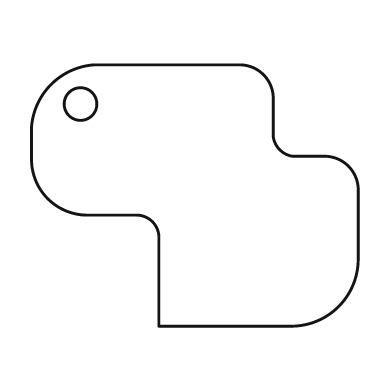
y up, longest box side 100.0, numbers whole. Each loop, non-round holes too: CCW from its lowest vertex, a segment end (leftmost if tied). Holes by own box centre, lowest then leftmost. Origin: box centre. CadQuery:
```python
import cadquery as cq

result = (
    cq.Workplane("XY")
    .moveTo(-11.0, -40.0)
    .lineTo(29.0, -40.0)
    .threePointArc((44.0, -34.0), (50.0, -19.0))
    .lineTo(50.0, 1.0)
    .threePointArc((47.0, 9.0), (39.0, 12.0))
    .lineTo(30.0, 12.0)
    .threePointArc((26.0, 14.0), (24.0, 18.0))
    .lineTo(24.0, 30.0)
    .threePointArc((21.0, 37.0), (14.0, 40.0))
    .lineTo(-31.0, 40.0)
    .threePointArc((-44.0, 34.0), (-50.0, 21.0))
    .lineTo(-50.0, 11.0)
    .threePointArc((-45.0, -1.0), (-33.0, -6.0))
    .lineTo(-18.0, -6.0)
    .threePointArc((-13.0, -8.0), (-11.0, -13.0))
    .close()
    .moveTo(-35.0, 28.0)
    .circle(5.0)
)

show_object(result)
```